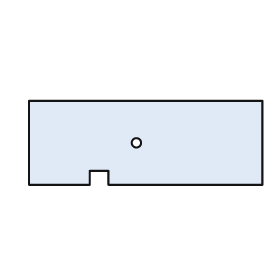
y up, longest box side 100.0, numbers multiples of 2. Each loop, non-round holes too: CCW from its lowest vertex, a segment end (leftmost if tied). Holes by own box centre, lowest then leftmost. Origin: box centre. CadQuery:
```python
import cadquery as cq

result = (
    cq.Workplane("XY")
    .moveTo(-50.0, -18.0)
    .lineTo(-24.0, -18.0)
    .lineTo(-24.0, -12.0)
    .lineTo(-16.0, -12.0)
    .lineTo(-16.0, -18.0)
    .lineTo(50.0, -18.0)
    .lineTo(50.0, 18.0)
    .lineTo(-50.0, 18.0)
    .close()
    .moveTo(-4.0, 0.0)
    .circle(2.0)
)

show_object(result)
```